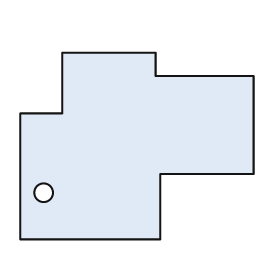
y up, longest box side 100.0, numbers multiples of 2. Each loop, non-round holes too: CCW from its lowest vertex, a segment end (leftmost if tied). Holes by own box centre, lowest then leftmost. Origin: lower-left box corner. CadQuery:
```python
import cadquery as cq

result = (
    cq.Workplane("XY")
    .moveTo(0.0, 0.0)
    .lineTo(60.0, 0.0)
    .lineTo(60.0, 28.0)
    .lineTo(100.0, 28.0)
    .lineTo(100.0, 70.0)
    .lineTo(58.0, 70.0)
    .lineTo(58.0, 80.0)
    .lineTo(18.0, 80.0)
    .lineTo(18.0, 54.0)
    .lineTo(0.0, 54.0)
    .close()
    .moveTo(10.0, 20.0)
    .circle(4.0)
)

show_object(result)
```